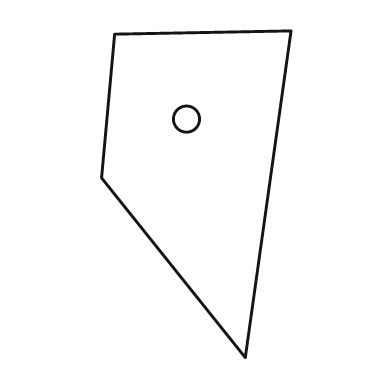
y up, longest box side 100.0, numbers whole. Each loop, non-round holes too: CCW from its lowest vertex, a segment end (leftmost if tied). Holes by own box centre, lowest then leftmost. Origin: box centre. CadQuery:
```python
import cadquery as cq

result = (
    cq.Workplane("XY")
    .moveTo(15.0, -50.0)
    .lineTo(29.0, 50.0)
    .lineTo(-25.0, 49.0)
    .lineTo(-29.0, 5.0)
    .close()
    .moveTo(-3.0, 23.0)
    .circle(4.0)
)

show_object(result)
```